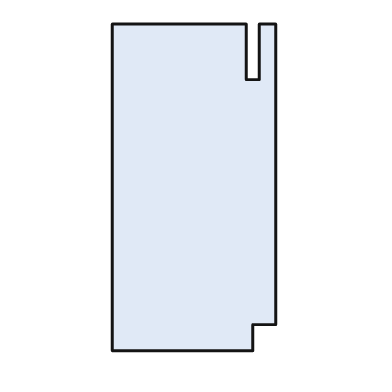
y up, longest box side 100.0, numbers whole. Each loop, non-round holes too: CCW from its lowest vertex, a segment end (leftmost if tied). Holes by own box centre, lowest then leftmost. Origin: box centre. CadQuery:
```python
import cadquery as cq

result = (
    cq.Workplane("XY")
    .moveTo(-25.0, -50.0)
    .lineTo(18.0, -50.0)
    .lineTo(18.0, -42.0)
    .lineTo(25.0, -42.0)
    .lineTo(25.0, 50.0)
    .lineTo(20.0, 50.0)
    .lineTo(20.0, 33.0)
    .lineTo(16.0, 33.0)
    .lineTo(16.0, 50.0)
    .lineTo(-25.0, 50.0)
    .close()
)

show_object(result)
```